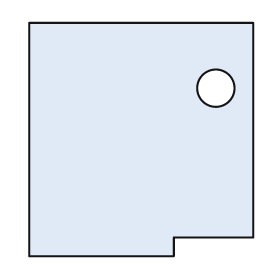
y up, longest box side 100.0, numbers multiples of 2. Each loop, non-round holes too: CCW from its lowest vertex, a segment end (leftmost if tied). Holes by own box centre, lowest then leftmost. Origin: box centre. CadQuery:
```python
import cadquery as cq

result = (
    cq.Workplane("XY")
    .moveTo(-48.0, -50.0)
    .lineTo(14.0, -50.0)
    .lineTo(14.0, -42.0)
    .lineTo(48.0, -42.0)
    .lineTo(48.0, 50.0)
    .lineTo(-48.0, 50.0)
    .close()
    .moveTo(32.0, 22.0)
    .circle(8.0)
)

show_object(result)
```